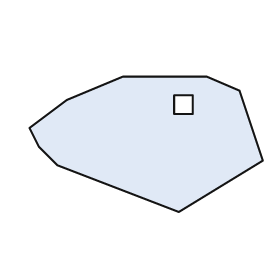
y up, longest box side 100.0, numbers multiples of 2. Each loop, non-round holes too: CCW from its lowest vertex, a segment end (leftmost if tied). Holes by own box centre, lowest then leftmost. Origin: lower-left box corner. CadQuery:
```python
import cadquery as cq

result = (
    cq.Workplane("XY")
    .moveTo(64.0, 0.0)
    .lineTo(100.0, 22.0)
    .lineTo(90.0, 52.0)
    .lineTo(76.0, 58.0)
    .lineTo(40.0, 58.0)
    .lineTo(16.0, 48.0)
    .lineTo(0.0, 36.0)
    .lineTo(4.0, 28.0)
    .lineTo(12.0, 20.0)
    .close()
    .moveTo(62.0, 42.0)
    .lineTo(70.0, 42.0)
    .lineTo(70.0, 50.0)
    .lineTo(62.0, 50.0)
    .close()
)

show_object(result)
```